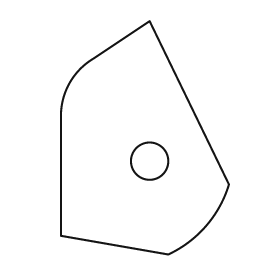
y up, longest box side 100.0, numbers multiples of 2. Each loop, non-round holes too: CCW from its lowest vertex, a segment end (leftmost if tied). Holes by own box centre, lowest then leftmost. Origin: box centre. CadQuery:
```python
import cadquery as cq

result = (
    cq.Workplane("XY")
    .moveTo(10.0, -50.0)
    .threePointArc((26.0, -38.0), (36.0, -20.0))
    .lineTo(2.0, 50.0)
    .lineTo(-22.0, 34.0)
    .threePointArc((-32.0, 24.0), (-36.0, 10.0))
    .lineTo(-36.0, -42.0)
    .close()
    .moveTo(2.0, -10.0)
    .circle(8.0)
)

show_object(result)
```